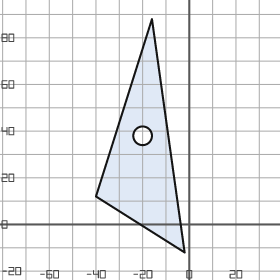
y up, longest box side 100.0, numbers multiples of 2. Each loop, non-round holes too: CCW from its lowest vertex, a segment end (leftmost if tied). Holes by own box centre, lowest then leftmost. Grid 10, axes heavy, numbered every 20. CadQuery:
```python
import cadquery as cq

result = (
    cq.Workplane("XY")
    .moveTo(-2.0, -12.0)
    .lineTo(-16.0, 88.0)
    .lineTo(-40.0, 12.0)
    .close()
    .moveTo(-20.0, 38.0)
    .circle(4.0)
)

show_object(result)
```